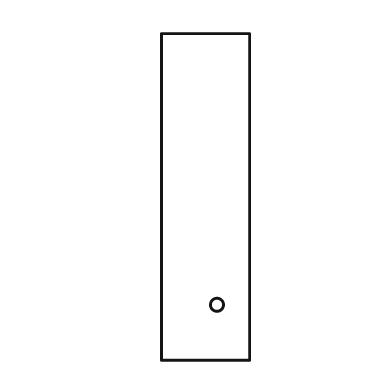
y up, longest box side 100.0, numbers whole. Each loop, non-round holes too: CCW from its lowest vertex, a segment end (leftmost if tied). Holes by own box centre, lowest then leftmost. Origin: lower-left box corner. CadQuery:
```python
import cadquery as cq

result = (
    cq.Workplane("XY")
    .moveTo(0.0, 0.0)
    .lineTo(27.0, 0.0)
    .lineTo(27.0, 100.0)
    .lineTo(0.0, 100.0)
    .close()
    .moveTo(17.0, 17.0)
    .circle(2.0)
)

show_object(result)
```